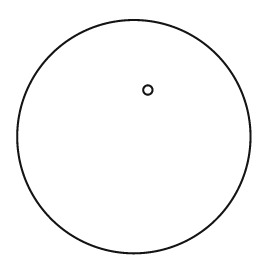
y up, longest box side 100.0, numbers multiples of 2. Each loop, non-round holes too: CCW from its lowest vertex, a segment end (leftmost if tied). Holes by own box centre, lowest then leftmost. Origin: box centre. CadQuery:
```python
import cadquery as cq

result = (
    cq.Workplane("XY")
    .moveTo(0.0, 0.0)
    .circle(50.0)
    .moveTo(6.0, 20.0)
    .circle(2.0)
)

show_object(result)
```